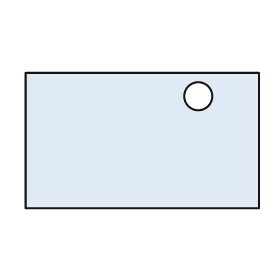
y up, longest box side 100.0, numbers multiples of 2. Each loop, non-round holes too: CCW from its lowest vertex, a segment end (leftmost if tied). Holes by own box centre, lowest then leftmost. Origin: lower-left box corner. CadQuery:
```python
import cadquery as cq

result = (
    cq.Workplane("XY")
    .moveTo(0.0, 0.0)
    .lineTo(100.0, 0.0)
    .lineTo(100.0, 58.0)
    .lineTo(0.0, 58.0)
    .close()
    .moveTo(74.0, 48.0)
    .circle(6.0)
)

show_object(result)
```